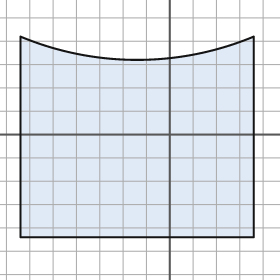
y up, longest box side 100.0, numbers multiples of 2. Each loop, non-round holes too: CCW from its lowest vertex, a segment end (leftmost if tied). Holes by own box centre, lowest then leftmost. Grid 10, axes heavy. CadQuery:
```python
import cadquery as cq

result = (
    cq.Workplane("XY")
    .moveTo(-64.0, -44.0)
    .lineTo(36.0, -44.0)
    .lineTo(36.0, 42.0)
    .threePointArc((-14.0, 32.0), (-64.0, 42.0))
    .close()
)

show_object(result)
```